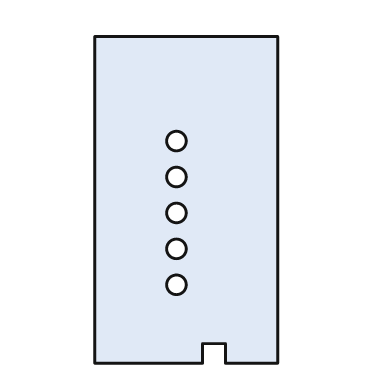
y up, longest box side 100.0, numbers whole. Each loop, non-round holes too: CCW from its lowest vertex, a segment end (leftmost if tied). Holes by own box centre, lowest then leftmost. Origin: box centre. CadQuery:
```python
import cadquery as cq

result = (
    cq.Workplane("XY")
    .moveTo(-28.0, -50.0)
    .lineTo(5.0, -50.0)
    .lineTo(5.0, -44.0)
    .lineTo(12.0, -44.0)
    .lineTo(12.0, -50.0)
    .lineTo(28.0, -50.0)
    .lineTo(28.0, 50.0)
    .lineTo(-28.0, 50.0)
    .close()
    .moveTo(-3.0, -26.0)
    .circle(3.0)
    .moveTo(-3.0, -15.0)
    .circle(3.0)
    .moveTo(-3.0, -4.0)
    .circle(3.0)
    .moveTo(-3.0, 7.0)
    .circle(3.0)
    .moveTo(-3.0, 18.0)
    .circle(3.0)
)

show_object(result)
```